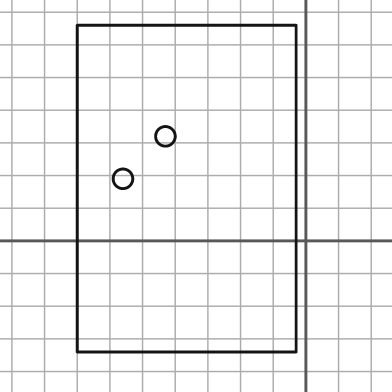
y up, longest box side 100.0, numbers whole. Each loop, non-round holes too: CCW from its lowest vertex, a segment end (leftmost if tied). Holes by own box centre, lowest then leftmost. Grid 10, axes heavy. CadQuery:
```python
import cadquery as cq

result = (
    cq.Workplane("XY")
    .moveTo(-70.0, -34.0)
    .lineTo(-3.0, -34.0)
    .lineTo(-3.0, 66.0)
    .lineTo(-70.0, 66.0)
    .close()
    .moveTo(-56.0, 19.0)
    .circle(3.0)
    .moveTo(-43.0, 32.0)
    .circle(3.0)
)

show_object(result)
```